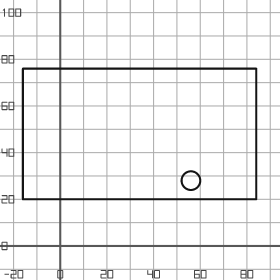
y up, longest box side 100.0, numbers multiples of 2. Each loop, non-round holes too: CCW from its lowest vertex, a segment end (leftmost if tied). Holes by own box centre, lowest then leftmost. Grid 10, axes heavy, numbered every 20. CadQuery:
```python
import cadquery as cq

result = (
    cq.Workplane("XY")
    .moveTo(-16.0, 20.0)
    .lineTo(84.0, 20.0)
    .lineTo(84.0, 76.0)
    .lineTo(-16.0, 76.0)
    .close()
    .moveTo(56.0, 28.0)
    .circle(4.0)
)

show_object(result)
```